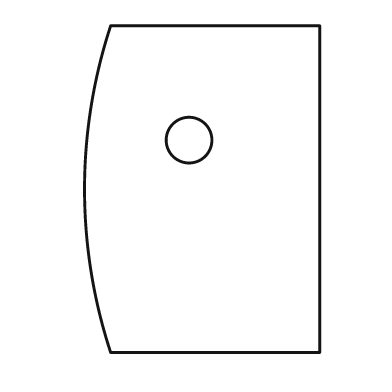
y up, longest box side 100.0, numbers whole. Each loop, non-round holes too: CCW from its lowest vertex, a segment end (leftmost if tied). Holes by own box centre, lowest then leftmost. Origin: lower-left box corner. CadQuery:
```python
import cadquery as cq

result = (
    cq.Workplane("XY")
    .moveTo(8.0, 0.0)
    .lineTo(72.0, 0.0)
    .lineTo(72.0, 100.0)
    .lineTo(8.0, 100.0)
    .threePointArc((0.0, 50.0), (8.0, 0.0))
    .close()
    .moveTo(32.0, 65.0)
    .circle(7.0)
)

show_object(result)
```